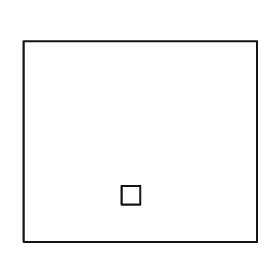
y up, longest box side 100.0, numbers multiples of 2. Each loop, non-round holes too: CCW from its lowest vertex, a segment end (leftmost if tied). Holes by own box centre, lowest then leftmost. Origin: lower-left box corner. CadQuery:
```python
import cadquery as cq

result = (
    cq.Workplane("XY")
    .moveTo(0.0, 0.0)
    .lineTo(100.0, 0.0)
    .lineTo(100.0, 86.0)
    .lineTo(0.0, 86.0)
    .close()
    .moveTo(42.0, 16.0)
    .lineTo(50.0, 16.0)
    .lineTo(50.0, 24.0)
    .lineTo(42.0, 24.0)
    .close()
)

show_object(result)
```